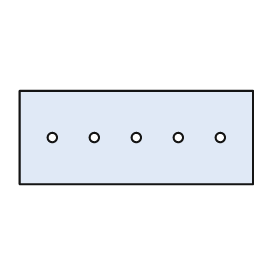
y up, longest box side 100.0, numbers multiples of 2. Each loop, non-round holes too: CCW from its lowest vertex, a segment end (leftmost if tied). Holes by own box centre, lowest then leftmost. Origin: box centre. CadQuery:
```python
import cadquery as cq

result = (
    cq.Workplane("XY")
    .moveTo(-50.0, -20.0)
    .lineTo(50.0, -20.0)
    .lineTo(50.0, 20.0)
    .lineTo(-50.0, 20.0)
    .close()
    .moveTo(-36.0, 0.0)
    .circle(2.0)
    .moveTo(-18.0, 0.0)
    .circle(2.0)
    .moveTo(0.0, 0.0)
    .circle(2.0)
    .moveTo(18.0, 0.0)
    .circle(2.0)
    .moveTo(36.0, 0.0)
    .circle(2.0)
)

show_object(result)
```